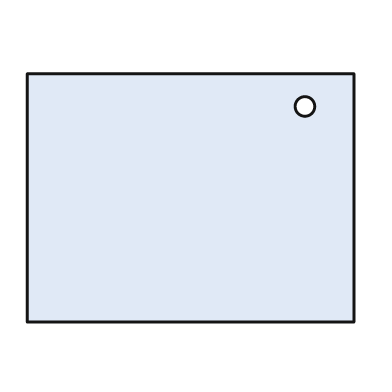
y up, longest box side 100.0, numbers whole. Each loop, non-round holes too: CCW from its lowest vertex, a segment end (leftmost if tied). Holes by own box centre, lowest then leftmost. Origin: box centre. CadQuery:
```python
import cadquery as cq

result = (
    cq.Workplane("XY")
    .moveTo(-50.0, -38.0)
    .lineTo(50.0, -38.0)
    .lineTo(50.0, 38.0)
    .lineTo(-50.0, 38.0)
    .close()
    .moveTo(35.0, 28.0)
    .circle(3.0)
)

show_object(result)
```